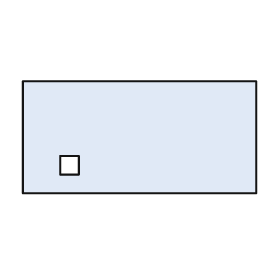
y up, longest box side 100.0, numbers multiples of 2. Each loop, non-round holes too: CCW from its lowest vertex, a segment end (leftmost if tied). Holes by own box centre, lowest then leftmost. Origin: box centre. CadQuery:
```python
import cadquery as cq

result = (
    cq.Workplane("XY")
    .moveTo(-50.0, -24.0)
    .lineTo(50.0, -24.0)
    .lineTo(50.0, 24.0)
    .lineTo(-50.0, 24.0)
    .close()
    .moveTo(-34.0, -16.0)
    .lineTo(-26.0, -16.0)
    .lineTo(-26.0, -8.0)
    .lineTo(-34.0, -8.0)
    .close()
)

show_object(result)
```